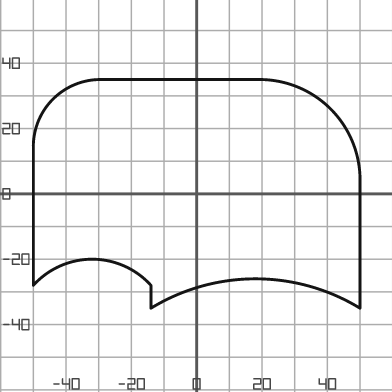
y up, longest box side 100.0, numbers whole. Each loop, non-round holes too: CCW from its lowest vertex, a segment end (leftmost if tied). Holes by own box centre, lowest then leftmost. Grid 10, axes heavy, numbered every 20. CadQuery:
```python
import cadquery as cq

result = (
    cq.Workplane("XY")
    .moveTo(-14.0, -35.0)
    .threePointArc((18.0, -26.0), (50.0, -35.0))
    .lineTo(50.0, 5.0)
    .threePointArc((41.0, 26.0), (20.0, 35.0))
    .lineTo(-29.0, 35.0)
    .threePointArc((-44.0, 29.0), (-50.0, 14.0))
    .lineTo(-50.0, -28.0)
    .threePointArc((-32.0, -20.0), (-14.0, -28.0))
    .close()
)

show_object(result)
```